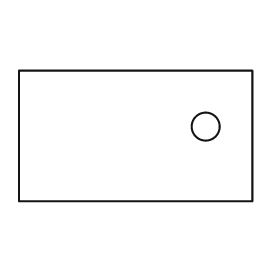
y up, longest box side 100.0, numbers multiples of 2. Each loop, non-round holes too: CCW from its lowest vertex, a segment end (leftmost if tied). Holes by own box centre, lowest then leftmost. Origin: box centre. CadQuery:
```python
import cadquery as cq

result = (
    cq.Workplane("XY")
    .moveTo(-50.0, -28.0)
    .lineTo(50.0, -28.0)
    .lineTo(50.0, 28.0)
    .lineTo(-50.0, 28.0)
    .close()
    .moveTo(30.0, 4.0)
    .circle(6.0)
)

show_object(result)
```